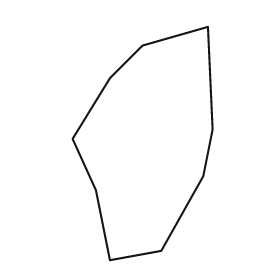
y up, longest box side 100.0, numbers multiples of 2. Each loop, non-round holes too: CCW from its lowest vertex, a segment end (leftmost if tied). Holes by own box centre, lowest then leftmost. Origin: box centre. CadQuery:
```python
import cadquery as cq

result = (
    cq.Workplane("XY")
    .moveTo(-14.0, -50.0)
    .lineTo(8.0, -46.0)
    .lineTo(26.0, -14.0)
    .lineTo(30.0, 6.0)
    .lineTo(28.0, 50.0)
    .lineTo(0.0, 42.0)
    .lineTo(-14.0, 28.0)
    .lineTo(-30.0, 2.0)
    .lineTo(-20.0, -20.0)
    .close()
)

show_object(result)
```